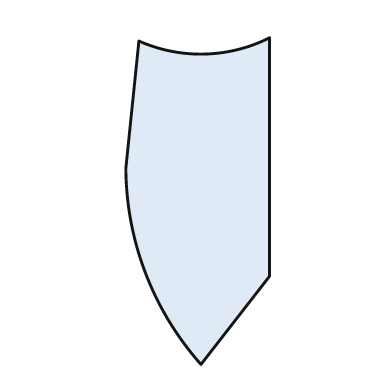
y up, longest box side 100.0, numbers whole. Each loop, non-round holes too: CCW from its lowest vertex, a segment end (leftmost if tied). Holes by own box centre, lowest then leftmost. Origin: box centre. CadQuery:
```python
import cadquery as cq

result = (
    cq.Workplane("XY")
    .moveTo(1.0, -50.0)
    .lineTo(22.0, -23.0)
    .lineTo(22.0, 50.0)
    .threePointArc((2.0, 45.0), (-18.0, 49.0))
    .lineTo(-22.0, 10.0)
    .threePointArc((-16.0, -22.0), (1.0, -50.0))
    .close()
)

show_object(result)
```